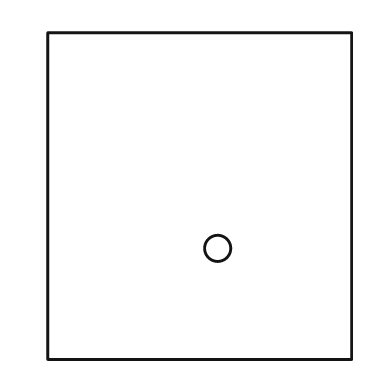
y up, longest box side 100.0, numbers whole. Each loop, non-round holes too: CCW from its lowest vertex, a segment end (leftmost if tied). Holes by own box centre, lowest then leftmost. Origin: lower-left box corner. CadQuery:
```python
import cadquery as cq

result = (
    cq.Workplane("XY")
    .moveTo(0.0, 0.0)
    .lineTo(93.0, 0.0)
    .lineTo(93.0, 100.0)
    .lineTo(0.0, 100.0)
    .close()
    .moveTo(52.0, 34.0)
    .circle(4.0)
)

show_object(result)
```